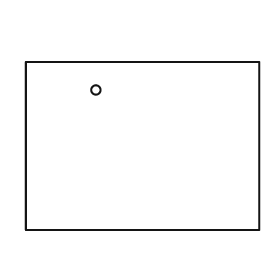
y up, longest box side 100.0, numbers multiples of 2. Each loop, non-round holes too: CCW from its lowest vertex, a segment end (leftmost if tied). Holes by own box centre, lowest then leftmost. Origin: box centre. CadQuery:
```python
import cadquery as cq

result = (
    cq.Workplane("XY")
    .moveTo(-50.0, -36.0)
    .lineTo(50.0, -36.0)
    .lineTo(50.0, 36.0)
    .lineTo(-50.0, 36.0)
    .close()
    .moveTo(-20.0, 24.0)
    .circle(2.0)
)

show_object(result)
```